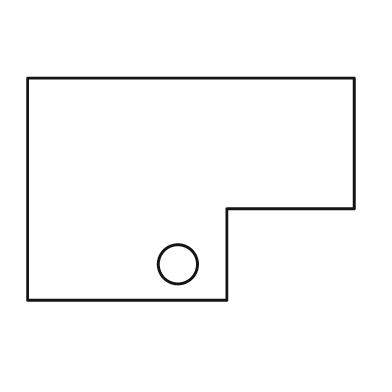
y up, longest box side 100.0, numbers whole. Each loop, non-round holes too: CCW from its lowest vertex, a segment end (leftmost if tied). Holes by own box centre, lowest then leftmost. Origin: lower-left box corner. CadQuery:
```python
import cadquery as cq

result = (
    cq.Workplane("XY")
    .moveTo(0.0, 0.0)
    .lineTo(61.0, 0.0)
    .lineTo(61.0, 28.0)
    .lineTo(100.0, 28.0)
    .lineTo(100.0, 68.0)
    .lineTo(0.0, 68.0)
    .close()
    .moveTo(46.0, 11.0)
    .circle(6.0)
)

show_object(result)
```